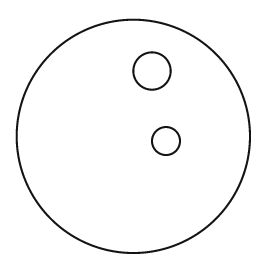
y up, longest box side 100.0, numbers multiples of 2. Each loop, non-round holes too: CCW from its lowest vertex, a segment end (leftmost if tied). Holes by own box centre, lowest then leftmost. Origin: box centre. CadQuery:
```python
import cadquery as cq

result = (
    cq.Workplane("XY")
    .moveTo(0.0, 0.0)
    .circle(50.0)
    .moveTo(14.0, -2.0)
    .circle(6.0)
    .moveTo(8.0, 28.0)
    .circle(8.0)
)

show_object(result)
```